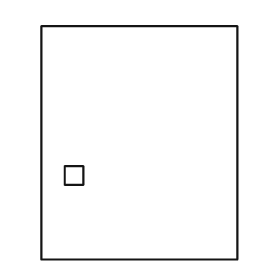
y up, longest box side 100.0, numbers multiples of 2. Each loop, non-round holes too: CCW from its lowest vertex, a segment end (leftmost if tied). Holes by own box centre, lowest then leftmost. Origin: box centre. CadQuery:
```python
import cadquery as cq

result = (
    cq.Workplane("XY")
    .moveTo(-42.0, -50.0)
    .lineTo(42.0, -50.0)
    .lineTo(42.0, 50.0)
    .lineTo(-42.0, 50.0)
    .close()
    .moveTo(-32.0, -18.0)
    .lineTo(-24.0, -18.0)
    .lineTo(-24.0, -10.0)
    .lineTo(-32.0, -10.0)
    .close()
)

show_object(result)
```